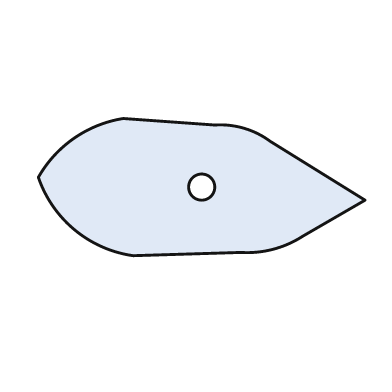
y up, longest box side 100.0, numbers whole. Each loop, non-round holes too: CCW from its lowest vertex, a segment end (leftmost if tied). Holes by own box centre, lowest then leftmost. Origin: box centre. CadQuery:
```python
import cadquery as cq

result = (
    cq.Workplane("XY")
    .moveTo(-21.0, -21.0)
    .lineTo(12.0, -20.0)
    .threePointArc((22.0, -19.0), (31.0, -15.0))
    .lineTo(50.0, -4.0)
    .lineTo(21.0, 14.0)
    .threePointArc((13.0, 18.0), (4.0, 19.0))
    .lineTo(-24.0, 21.0)
    .threePointArc((-39.0, 15.0), (-50.0, 3.0))
    .threePointArc((-39.0, -13.0), (-21.0, -21.0))
    .close()
    .moveTo(0.0, 0.0)
    .circle(4.0)
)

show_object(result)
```